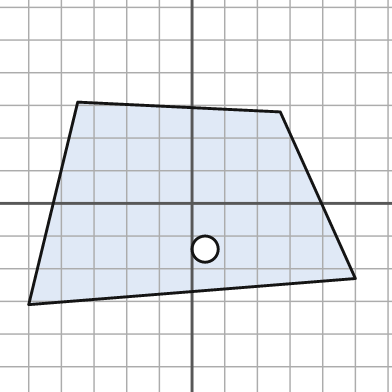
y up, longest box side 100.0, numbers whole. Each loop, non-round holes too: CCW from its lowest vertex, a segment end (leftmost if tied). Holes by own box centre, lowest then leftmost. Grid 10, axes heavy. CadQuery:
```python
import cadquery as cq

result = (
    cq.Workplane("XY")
    .moveTo(-50.0, -31.0)
    .lineTo(50.0, -23.0)
    .lineTo(27.0, 28.0)
    .lineTo(-35.0, 31.0)
    .close()
    .moveTo(4.0, -14.0)
    .circle(4.0)
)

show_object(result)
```